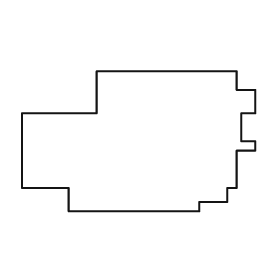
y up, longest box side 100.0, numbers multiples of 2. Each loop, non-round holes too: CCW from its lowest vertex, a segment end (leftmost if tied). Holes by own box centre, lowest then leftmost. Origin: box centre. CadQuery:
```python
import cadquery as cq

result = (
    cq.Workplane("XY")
    .moveTo(-30.0, -30.0)
    .lineTo(26.0, -30.0)
    .lineTo(26.0, -26.0)
    .lineTo(38.0, -26.0)
    .lineTo(38.0, -20.0)
    .lineTo(42.0, -20.0)
    .lineTo(42.0, -4.0)
    .lineTo(50.0, -4.0)
    .lineTo(50.0, 0.0)
    .lineTo(44.0, 0.0)
    .lineTo(44.0, 12.0)
    .lineTo(50.0, 12.0)
    .lineTo(50.0, 22.0)
    .lineTo(42.0, 22.0)
    .lineTo(42.0, 30.0)
    .lineTo(-18.0, 30.0)
    .lineTo(-18.0, 12.0)
    .lineTo(-50.0, 12.0)
    .lineTo(-50.0, -20.0)
    .lineTo(-30.0, -20.0)
    .close()
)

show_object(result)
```